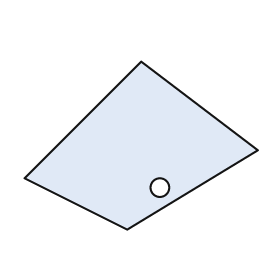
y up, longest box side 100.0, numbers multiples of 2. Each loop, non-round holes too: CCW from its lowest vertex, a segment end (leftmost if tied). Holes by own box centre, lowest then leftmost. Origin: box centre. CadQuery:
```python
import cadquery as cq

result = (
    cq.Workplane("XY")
    .moveTo(-6.0, -36.0)
    .lineTo(50.0, -2.0)
    .lineTo(0.0, 36.0)
    .lineTo(-50.0, -14.0)
    .close()
    .moveTo(8.0, -18.0)
    .circle(4.0)
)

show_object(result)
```